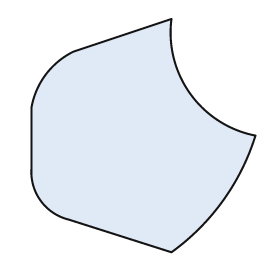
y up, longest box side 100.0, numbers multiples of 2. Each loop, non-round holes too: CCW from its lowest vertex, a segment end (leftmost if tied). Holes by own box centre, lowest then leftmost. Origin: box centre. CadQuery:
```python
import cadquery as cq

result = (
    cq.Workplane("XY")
    .moveTo(12.0, -50.0)
    .threePointArc((34.0, -28.0), (48.0, 0.0))
    .threePointArc((20.0, 18.0), (12.0, 50.0))
    .lineTo(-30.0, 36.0)
    .threePointArc((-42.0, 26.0), (-48.0, 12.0))
    .lineTo(-48.0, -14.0)
    .threePointArc((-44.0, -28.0), (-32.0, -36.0))
    .close()
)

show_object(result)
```